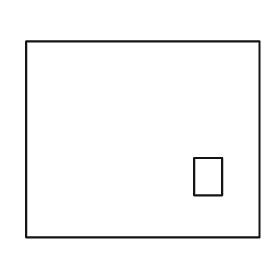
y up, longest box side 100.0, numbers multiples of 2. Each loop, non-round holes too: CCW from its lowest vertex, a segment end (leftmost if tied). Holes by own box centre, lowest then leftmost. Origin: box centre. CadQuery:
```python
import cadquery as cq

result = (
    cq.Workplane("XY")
    .moveTo(-50.0, -42.0)
    .lineTo(50.0, -42.0)
    .lineTo(50.0, 42.0)
    .lineTo(-50.0, 42.0)
    .close()
    .moveTo(22.0, -24.0)
    .lineTo(34.0, -24.0)
    .lineTo(34.0, -8.0)
    .lineTo(22.0, -8.0)
    .close()
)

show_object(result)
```